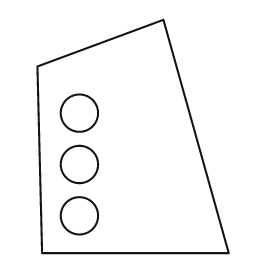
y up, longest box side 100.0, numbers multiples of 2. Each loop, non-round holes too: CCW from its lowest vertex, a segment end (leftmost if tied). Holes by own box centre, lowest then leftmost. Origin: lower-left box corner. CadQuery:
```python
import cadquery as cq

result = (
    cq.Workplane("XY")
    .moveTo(2.0, 0.0)
    .lineTo(82.0, 0.0)
    .lineTo(54.0, 100.0)
    .lineTo(0.0, 80.0)
    .close()
    .moveTo(18.0, 16.0)
    .circle(8.0)
    .moveTo(18.0, 38.0)
    .circle(8.0)
    .moveTo(18.0, 60.0)
    .circle(8.0)
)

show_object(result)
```